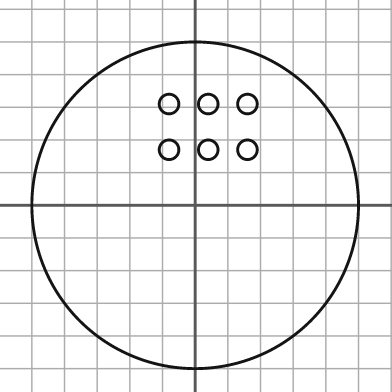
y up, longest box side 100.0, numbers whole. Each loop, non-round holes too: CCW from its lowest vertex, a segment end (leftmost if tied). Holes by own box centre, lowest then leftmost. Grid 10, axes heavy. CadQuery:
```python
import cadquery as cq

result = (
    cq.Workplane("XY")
    .moveTo(0.0, 0.0)
    .circle(50.0)
    .moveTo(-8.0, 17.0)
    .circle(3.0)
    .moveTo(4.0, 17.0)
    .circle(3.0)
    .moveTo(16.0, 17.0)
    .circle(3.0)
    .moveTo(-8.0, 31.0)
    .circle(3.0)
    .moveTo(4.0, 31.0)
    .circle(3.0)
    .moveTo(16.0, 31.0)
    .circle(3.0)
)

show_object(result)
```